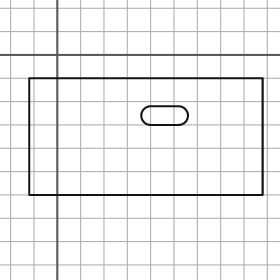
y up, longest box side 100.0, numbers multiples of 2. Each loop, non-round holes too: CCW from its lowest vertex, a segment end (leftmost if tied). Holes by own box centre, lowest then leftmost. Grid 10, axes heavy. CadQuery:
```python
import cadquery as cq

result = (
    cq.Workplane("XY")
    .moveTo(-12.0, -60.0)
    .lineTo(88.0, -60.0)
    .lineTo(88.0, -10.0)
    .lineTo(-12.0, -10.0)
    .close()
    .moveTo(40.0, -30.0)
    .lineTo(52.0, -30.0)
    .threePointArc((56.0, -26.0), (52.0, -22.0))
    .lineTo(40.0, -22.0)
    .threePointArc((36.0, -26.0), (40.0, -30.0))
    .close()
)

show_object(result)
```